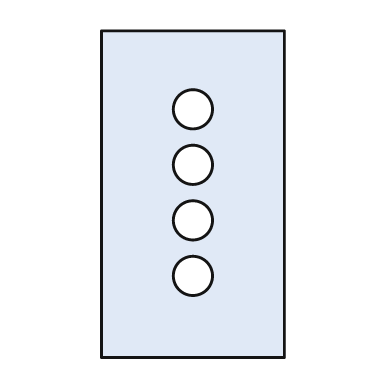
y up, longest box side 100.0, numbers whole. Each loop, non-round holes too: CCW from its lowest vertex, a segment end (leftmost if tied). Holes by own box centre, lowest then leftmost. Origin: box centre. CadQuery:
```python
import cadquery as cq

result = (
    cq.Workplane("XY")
    .moveTo(-28.0, -50.0)
    .lineTo(28.0, -50.0)
    .lineTo(28.0, 50.0)
    .lineTo(-28.0, 50.0)
    .close()
    .moveTo(0.0, -25.0)
    .circle(6.0)
    .moveTo(0.0, -8.0)
    .circle(6.0)
    .moveTo(0.0, 9.0)
    .circle(6.0)
    .moveTo(0.0, 26.0)
    .circle(6.0)
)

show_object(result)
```